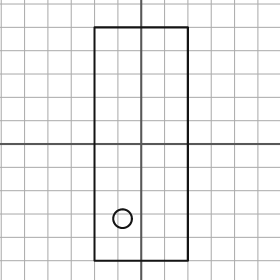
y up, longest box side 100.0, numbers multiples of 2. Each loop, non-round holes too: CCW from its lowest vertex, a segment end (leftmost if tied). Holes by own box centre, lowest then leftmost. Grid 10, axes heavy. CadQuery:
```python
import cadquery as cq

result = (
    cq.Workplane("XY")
    .moveTo(-20.0, -50.0)
    .lineTo(20.0, -50.0)
    .lineTo(20.0, 50.0)
    .lineTo(-20.0, 50.0)
    .close()
    .moveTo(-8.0, -32.0)
    .circle(4.0)
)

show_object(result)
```